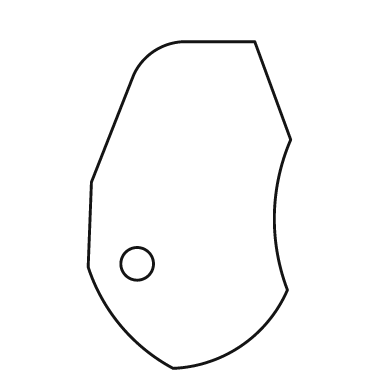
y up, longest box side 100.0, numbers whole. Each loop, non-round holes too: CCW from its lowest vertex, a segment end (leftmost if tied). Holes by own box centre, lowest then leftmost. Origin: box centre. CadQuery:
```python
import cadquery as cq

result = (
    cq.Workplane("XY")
    .moveTo(-5.0, -50.0)
    .threePointArc((16.0, -43.0), (30.0, -26.0))
    .threePointArc((26.0, -3.0), (31.0, 20.0))
    .lineTo(20.0, 50.0)
    .lineTo(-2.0, 50.0)
    .threePointArc((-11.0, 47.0), (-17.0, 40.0))
    .lineTo(-30.0, 7.0)
    .lineTo(-31.0, -19.0)
    .threePointArc((-21.0, -37.0), (-5.0, -50.0))
    .close()
    .moveTo(-16.0, -18.0)
    .circle(5.0)
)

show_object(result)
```